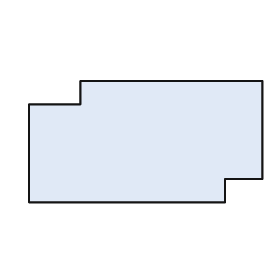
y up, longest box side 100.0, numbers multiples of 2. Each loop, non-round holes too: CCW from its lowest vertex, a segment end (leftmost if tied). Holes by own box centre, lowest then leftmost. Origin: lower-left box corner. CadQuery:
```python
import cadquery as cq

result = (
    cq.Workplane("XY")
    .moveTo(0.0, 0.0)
    .lineTo(84.0, 0.0)
    .lineTo(84.0, 10.0)
    .lineTo(100.0, 10.0)
    .lineTo(100.0, 52.0)
    .lineTo(22.0, 52.0)
    .lineTo(22.0, 42.0)
    .lineTo(0.0, 42.0)
    .close()
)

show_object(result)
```